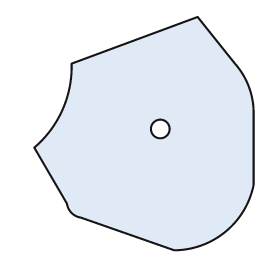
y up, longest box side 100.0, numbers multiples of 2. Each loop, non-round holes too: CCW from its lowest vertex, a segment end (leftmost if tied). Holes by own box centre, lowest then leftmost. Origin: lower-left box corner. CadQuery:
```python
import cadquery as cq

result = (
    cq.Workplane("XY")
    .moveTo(60.0, 0.0)
    .threePointArc((82.0, 8.0), (94.0, 28.0))
    .lineTo(94.0, 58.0)
    .threePointArc((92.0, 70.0), (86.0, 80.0))
    .lineTo(70.0, 100.0)
    .lineTo(16.0, 80.0)
    .threePointArc((12.0, 60.0), (0.0, 44.0))
    .lineTo(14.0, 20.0)
    .threePointArc((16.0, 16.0), (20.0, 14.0))
    .close()
    .moveTo(54.0, 52.0)
    .circle(4.0)
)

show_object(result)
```